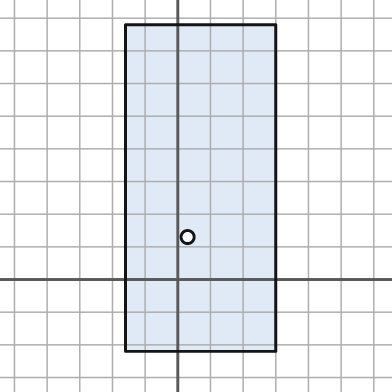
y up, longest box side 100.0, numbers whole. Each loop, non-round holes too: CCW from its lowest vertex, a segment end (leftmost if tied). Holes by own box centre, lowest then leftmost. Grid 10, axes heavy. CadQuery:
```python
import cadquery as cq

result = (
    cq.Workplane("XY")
    .moveTo(-16.0, -22.0)
    .lineTo(30.0, -22.0)
    .lineTo(30.0, 78.0)
    .lineTo(-16.0, 78.0)
    .close()
    .moveTo(3.0, 13.0)
    .circle(2.0)
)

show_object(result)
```